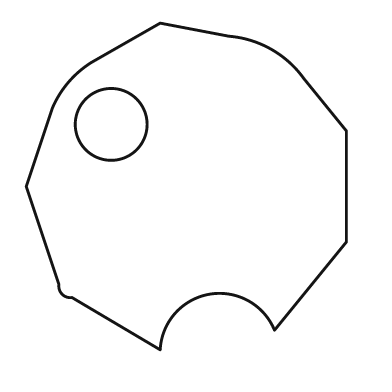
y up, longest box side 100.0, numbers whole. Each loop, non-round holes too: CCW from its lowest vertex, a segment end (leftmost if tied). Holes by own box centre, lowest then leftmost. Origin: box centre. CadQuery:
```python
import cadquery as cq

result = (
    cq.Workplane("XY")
    .moveTo(-8.0, -50.0)
    .threePointArc((7.0, -33.0), (27.0, -44.0))
    .lineTo(49.0, -17.0)
    .lineTo(49.0, 17.0)
    .lineTo(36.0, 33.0)
    .threePointArc((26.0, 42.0), (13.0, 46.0))
    .lineTo(-8.0, 50.0)
    .lineTo(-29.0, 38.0)
    .threePointArc((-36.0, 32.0), (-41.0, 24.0))
    .lineTo(-49.0, 0.0)
    .lineTo(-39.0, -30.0)
    .threePointArc((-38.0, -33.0), (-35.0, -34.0))
    .close()
    .moveTo(-23.0, 19.0)
    .circle(11.0)
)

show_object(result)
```